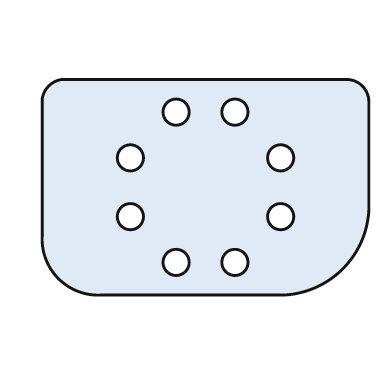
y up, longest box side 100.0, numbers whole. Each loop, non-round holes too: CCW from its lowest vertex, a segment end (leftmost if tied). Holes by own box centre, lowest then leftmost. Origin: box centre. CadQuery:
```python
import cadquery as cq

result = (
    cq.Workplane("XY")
    .moveTo(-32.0, -33.0)
    .lineTo(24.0, -33.0)
    .threePointArc((42.0, -25.0), (50.0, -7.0))
    .lineTo(50.0, 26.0)
    .threePointArc((48.0, 31.0), (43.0, 33.0))
    .lineTo(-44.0, 33.0)
    .threePointArc((-48.0, 31.0), (-50.0, 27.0))
    .lineTo(-50.0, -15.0)
    .threePointArc((-45.0, -28.0), (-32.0, -33.0))
    .close()
    .moveTo(-9.0, -23.0)
    .circle(4.0)
    .moveTo(9.0, -23.0)
    .circle(4.0)
    .moveTo(-23.0, -9.0)
    .circle(4.0)
    .moveTo(23.0, -9.0)
    .circle(4.0)
    .moveTo(-23.0, 9.0)
    .circle(4.0)
    .moveTo(23.0, 9.0)
    .circle(4.0)
    .moveTo(-9.0, 23.0)
    .circle(4.0)
    .moveTo(9.0, 23.0)
    .circle(4.0)
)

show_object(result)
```